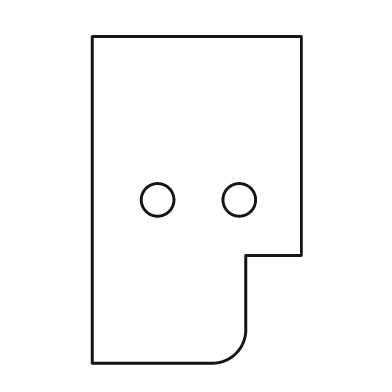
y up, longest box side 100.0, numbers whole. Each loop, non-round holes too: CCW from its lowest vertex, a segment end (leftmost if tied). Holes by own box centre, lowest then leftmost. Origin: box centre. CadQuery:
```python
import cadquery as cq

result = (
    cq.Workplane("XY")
    .moveTo(-32.0, -50.0)
    .lineTo(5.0, -50.0)
    .threePointArc((12.0, -47.0), (15.0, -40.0))
    .lineTo(15.0, -17.0)
    .lineTo(32.0, -17.0)
    .lineTo(32.0, 50.0)
    .lineTo(-32.0, 50.0)
    .close()
    .moveTo(-12.0, 0.0)
    .circle(5.0)
    .moveTo(13.0, 0.0)
    .circle(5.0)
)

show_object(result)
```